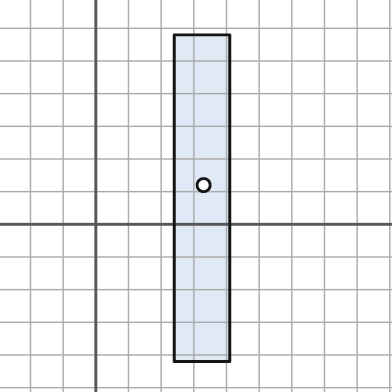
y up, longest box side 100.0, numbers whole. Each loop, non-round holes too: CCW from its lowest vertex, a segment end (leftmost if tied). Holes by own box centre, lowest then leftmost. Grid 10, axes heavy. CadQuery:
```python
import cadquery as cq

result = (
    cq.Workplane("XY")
    .moveTo(24.0, -42.0)
    .lineTo(41.0, -42.0)
    .lineTo(41.0, 58.0)
    .lineTo(24.0, 58.0)
    .close()
    .moveTo(33.0, 12.0)
    .circle(2.0)
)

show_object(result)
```